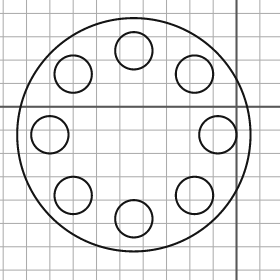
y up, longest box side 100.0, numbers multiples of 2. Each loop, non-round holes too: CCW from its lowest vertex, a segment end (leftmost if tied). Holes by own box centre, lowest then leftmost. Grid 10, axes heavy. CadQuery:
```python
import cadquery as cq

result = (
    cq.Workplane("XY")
    .moveTo(-44.0, -12.0)
    .circle(50.0)
    .moveTo(-44.0, -48.0)
    .circle(8.0)
    .moveTo(-70.0, -38.0)
    .circle(8.0)
    .moveTo(-18.0, -38.0)
    .circle(8.0)
    .moveTo(-80.0, -12.0)
    .circle(8.0)
    .moveTo(-8.0, -12.0)
    .circle(8.0)
    .moveTo(-70.0, 14.0)
    .circle(8.0)
    .moveTo(-18.0, 14.0)
    .circle(8.0)
    .moveTo(-44.0, 24.0)
    .circle(8.0)
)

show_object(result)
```